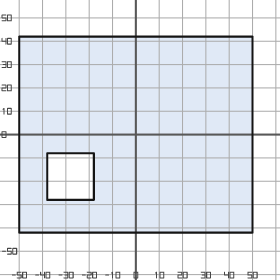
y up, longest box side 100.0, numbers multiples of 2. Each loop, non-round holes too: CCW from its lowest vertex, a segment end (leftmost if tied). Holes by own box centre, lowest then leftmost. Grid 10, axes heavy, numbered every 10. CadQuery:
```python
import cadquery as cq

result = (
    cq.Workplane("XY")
    .moveTo(-50.0, -42.0)
    .lineTo(50.0, -42.0)
    .lineTo(50.0, 42.0)
    .lineTo(-50.0, 42.0)
    .close()
    .moveTo(-38.0, -28.0)
    .lineTo(-18.0, -28.0)
    .lineTo(-18.0, -8.0)
    .lineTo(-38.0, -8.0)
    .close()
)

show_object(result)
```